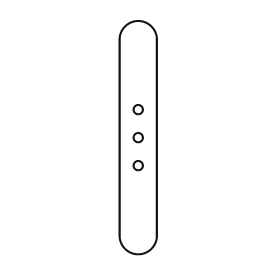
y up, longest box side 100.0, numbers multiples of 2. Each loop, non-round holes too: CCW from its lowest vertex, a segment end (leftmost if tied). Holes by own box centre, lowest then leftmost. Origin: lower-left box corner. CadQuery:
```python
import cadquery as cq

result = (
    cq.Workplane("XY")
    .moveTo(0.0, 8.0)
    .threePointArc((8.0, 0.0), (16.0, 8.0))
    .lineTo(16.0, 92.0)
    .threePointArc((8.0, 100.0), (0.0, 92.0))
    .close()
    .moveTo(8.0, 38.0)
    .circle(2.0)
    .moveTo(8.0, 50.0)
    .circle(2.0)
    .moveTo(8.0, 62.0)
    .circle(2.0)
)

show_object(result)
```